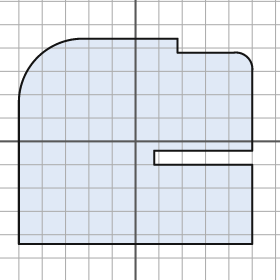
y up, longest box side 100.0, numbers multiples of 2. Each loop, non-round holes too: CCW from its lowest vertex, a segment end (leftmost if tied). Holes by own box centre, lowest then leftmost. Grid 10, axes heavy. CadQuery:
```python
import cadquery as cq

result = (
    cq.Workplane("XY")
    .moveTo(-50.0, -44.0)
    .lineTo(50.0, -44.0)
    .lineTo(50.0, -10.0)
    .lineTo(8.0, -10.0)
    .lineTo(8.0, -4.0)
    .lineTo(50.0, -4.0)
    .lineTo(50.0, 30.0)
    .threePointArc((48.0, 36.0), (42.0, 38.0))
    .lineTo(18.0, 38.0)
    .lineTo(18.0, 44.0)
    .lineTo(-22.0, 44.0)
    .threePointArc((-42.0, 36.0), (-50.0, 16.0))
    .close()
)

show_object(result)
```